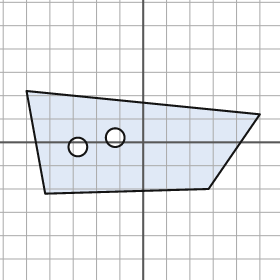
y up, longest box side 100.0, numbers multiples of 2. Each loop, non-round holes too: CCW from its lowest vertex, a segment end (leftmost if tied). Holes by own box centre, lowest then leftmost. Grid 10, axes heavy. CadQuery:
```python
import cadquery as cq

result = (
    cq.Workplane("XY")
    .moveTo(-42.0, -22.0)
    .lineTo(28.0, -20.0)
    .lineTo(50.0, 12.0)
    .lineTo(-50.0, 22.0)
    .close()
    .moveTo(-28.0, -2.0)
    .circle(4.0)
    .moveTo(-12.0, 2.0)
    .circle(4.0)
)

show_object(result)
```